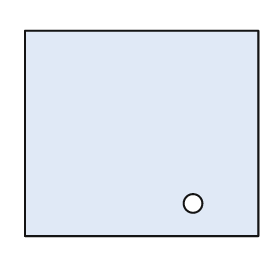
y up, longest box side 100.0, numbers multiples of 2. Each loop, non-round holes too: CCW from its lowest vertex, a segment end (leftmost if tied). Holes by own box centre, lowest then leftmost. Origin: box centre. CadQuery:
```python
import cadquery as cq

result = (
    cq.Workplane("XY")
    .moveTo(-50.0, -44.0)
    .lineTo(50.0, -44.0)
    .lineTo(50.0, 44.0)
    .lineTo(-50.0, 44.0)
    .close()
    .moveTo(22.0, -30.0)
    .circle(4.0)
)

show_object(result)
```